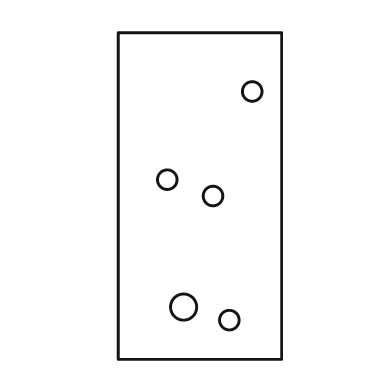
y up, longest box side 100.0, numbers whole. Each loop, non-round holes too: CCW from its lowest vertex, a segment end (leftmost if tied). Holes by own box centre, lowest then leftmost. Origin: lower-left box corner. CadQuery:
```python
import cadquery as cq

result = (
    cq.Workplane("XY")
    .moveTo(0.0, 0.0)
    .lineTo(50.0, 0.0)
    .lineTo(50.0, 100.0)
    .lineTo(0.0, 100.0)
    .close()
    .moveTo(34.0, 12.0)
    .circle(3.0)
    .moveTo(20.0, 16.0)
    .circle(4.0)
    .moveTo(29.0, 50.0)
    .circle(3.0)
    .moveTo(15.0, 55.0)
    .circle(3.0)
    .moveTo(41.0, 82.0)
    .circle(3.0)
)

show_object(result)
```